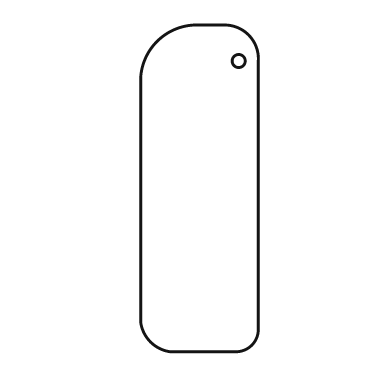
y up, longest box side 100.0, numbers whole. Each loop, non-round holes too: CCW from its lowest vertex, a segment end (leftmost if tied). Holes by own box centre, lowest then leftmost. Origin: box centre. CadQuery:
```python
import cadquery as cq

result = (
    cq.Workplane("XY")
    .moveTo(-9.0, -50.0)
    .lineTo(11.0, -50.0)
    .threePointArc((16.0, -48.0), (18.0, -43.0))
    .lineTo(18.0, 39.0)
    .threePointArc((15.0, 47.0), (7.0, 50.0))
    .lineTo(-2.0, 50.0)
    .threePointArc((-13.0, 45.0), (-18.0, 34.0))
    .lineTo(-18.0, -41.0)
    .threePointArc((-15.0, -47.0), (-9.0, -50.0))
    .close()
    .moveTo(12.0, 39.0)
    .circle(2.0)
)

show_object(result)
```